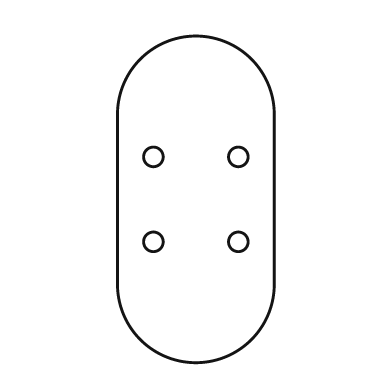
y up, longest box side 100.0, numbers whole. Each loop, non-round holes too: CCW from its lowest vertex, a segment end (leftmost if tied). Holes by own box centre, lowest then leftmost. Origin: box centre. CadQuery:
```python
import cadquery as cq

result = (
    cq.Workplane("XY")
    .moveTo(-24.0, -26.0)
    .threePointArc((0.0, -50.0), (24.0, -26.0))
    .lineTo(24.0, 26.0)
    .threePointArc((0.0, 50.0), (-24.0, 26.0))
    .close()
    .moveTo(-13.0, -13.0)
    .circle(3.0)
    .moveTo(13.0, -13.0)
    .circle(3.0)
    .moveTo(-13.0, 13.0)
    .circle(3.0)
    .moveTo(13.0, 13.0)
    .circle(3.0)
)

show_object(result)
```